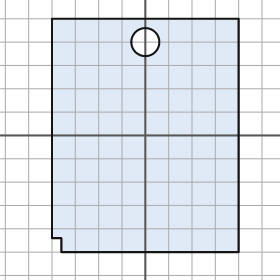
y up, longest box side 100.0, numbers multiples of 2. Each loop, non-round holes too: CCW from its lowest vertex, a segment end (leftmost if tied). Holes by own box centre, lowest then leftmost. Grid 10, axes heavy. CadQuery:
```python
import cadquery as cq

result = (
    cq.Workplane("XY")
    .moveTo(-36.0, -50.0)
    .lineTo(40.0, -50.0)
    .lineTo(40.0, 50.0)
    .lineTo(-40.0, 50.0)
    .lineTo(-40.0, -44.0)
    .lineTo(-36.0, -44.0)
    .close()
    .moveTo(0.0, 40.0)
    .circle(6.0)
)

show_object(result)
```